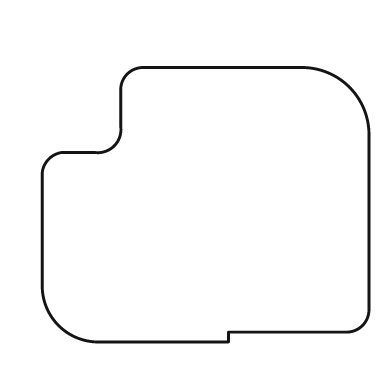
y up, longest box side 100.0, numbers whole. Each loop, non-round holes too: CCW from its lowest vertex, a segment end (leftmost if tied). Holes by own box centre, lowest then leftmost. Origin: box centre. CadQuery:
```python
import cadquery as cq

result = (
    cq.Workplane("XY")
    .moveTo(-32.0, -42.0)
    .lineTo(7.0, -42.0)
    .lineTo(7.0, -39.0)
    .lineTo(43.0, -39.0)
    .threePointArc((48.0, -37.0), (50.0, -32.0))
    .lineTo(50.0, 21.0)
    .threePointArc((44.0, 36.0), (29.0, 42.0))
    .lineTo(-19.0, 42.0)
    .threePointArc((-24.0, 40.0), (-26.0, 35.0))
    .lineTo(-26.0, 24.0)
    .threePointArc((-28.0, 18.0), (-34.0, 16.0))
    .lineTo(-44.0, 16.0)
    .threePointArc((-48.0, 14.0), (-50.0, 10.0))
    .lineTo(-50.0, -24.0)
    .threePointArc((-45.0, -37.0), (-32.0, -42.0))
    .close()
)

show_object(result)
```